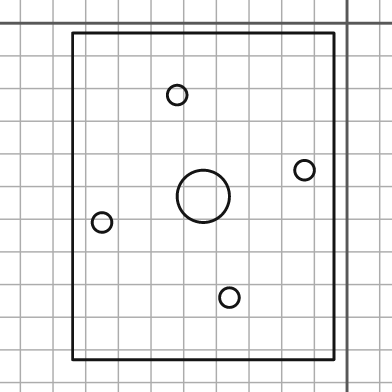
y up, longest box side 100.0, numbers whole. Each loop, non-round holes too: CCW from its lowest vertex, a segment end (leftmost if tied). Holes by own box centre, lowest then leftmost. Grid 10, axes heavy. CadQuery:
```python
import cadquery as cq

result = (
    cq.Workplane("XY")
    .moveTo(-84.0, -103.0)
    .lineTo(-4.0, -103.0)
    .lineTo(-4.0, -3.0)
    .lineTo(-84.0, -3.0)
    .close()
    .moveTo(-36.0, -84.0)
    .circle(3.0)
    .moveTo(-75.0, -61.0)
    .circle(3.0)
    .moveTo(-44.0, -53.0)
    .circle(8.0)
    .moveTo(-13.0, -45.0)
    .circle(3.0)
    .moveTo(-52.0, -22.0)
    .circle(3.0)
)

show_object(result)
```